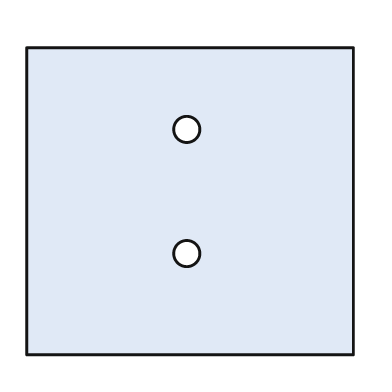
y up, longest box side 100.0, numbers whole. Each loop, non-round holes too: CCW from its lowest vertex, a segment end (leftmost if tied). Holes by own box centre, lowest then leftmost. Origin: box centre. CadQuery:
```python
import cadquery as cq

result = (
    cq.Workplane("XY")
    .moveTo(-50.0, -47.0)
    .lineTo(50.0, -47.0)
    .lineTo(50.0, 47.0)
    .lineTo(-50.0, 47.0)
    .close()
    .moveTo(-1.0, -16.0)
    .circle(4.0)
    .moveTo(-1.0, 22.0)
    .circle(4.0)
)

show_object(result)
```